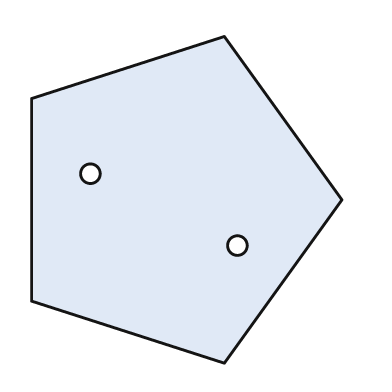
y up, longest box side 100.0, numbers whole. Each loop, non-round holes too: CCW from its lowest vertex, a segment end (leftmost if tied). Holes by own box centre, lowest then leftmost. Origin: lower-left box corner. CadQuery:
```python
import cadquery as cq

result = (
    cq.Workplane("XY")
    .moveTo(59.0, 0.0)
    .lineTo(95.0, 50.0)
    .lineTo(59.0, 100.0)
    .lineTo(0.0, 81.0)
    .lineTo(0.0, 19.0)
    .close()
    .moveTo(63.0, 36.0)
    .circle(3.0)
    .moveTo(18.0, 58.0)
    .circle(3.0)
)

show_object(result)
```